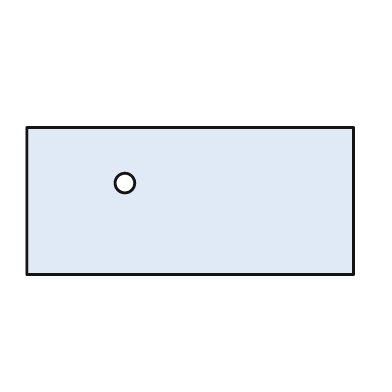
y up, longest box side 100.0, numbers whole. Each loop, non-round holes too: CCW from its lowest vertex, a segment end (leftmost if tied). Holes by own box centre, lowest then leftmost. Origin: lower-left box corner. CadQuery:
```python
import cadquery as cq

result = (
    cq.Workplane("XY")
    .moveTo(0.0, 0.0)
    .lineTo(100.0, 0.0)
    .lineTo(100.0, 45.0)
    .lineTo(0.0, 45.0)
    .close()
    .moveTo(30.0, 28.0)
    .circle(3.0)
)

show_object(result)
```